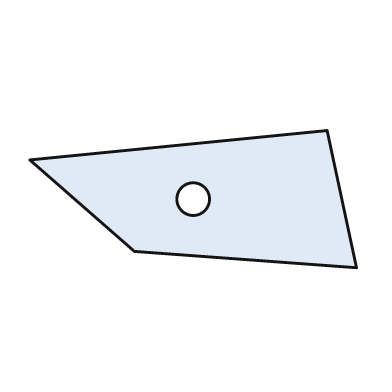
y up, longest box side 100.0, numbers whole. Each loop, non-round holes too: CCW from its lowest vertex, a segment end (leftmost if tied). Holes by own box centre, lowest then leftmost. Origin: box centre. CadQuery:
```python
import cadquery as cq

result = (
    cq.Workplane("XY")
    .moveTo(50.0, -21.0)
    .lineTo(41.0, 21.0)
    .lineTo(-50.0, 12.0)
    .lineTo(-18.0, -16.0)
    .close()
    .moveTo(0.0, 0.0)
    .circle(5.0)
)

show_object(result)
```